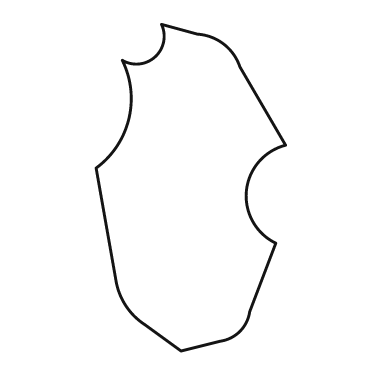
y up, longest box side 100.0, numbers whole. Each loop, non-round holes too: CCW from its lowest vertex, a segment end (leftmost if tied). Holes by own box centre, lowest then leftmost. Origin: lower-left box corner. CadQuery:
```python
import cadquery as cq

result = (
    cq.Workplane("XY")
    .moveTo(26.0, 0.0)
    .lineTo(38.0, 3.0)
    .threePointArc((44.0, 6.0), (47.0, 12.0))
    .lineTo(55.0, 33.0)
    .threePointArc((46.0, 49.0), (58.0, 63.0))
    .lineTo(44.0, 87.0)
    .threePointArc((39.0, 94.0), (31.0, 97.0))
    .lineTo(20.0, 100.0)
    .threePointArc((18.0, 90.0), (8.0, 89.0))
    .threePointArc((10.0, 71.0), (0.0, 56.0))
    .lineTo(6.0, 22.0)
    .threePointArc((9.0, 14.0), (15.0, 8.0))
    .close()
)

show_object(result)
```